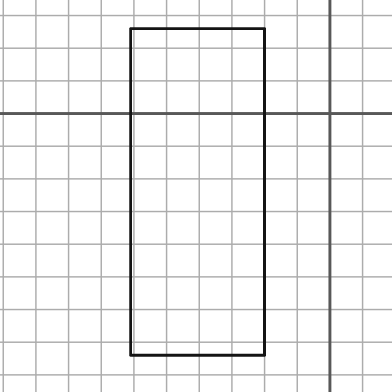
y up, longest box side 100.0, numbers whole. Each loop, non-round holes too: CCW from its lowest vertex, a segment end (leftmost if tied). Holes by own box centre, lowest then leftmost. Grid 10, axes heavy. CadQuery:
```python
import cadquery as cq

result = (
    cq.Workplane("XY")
    .moveTo(-61.0, -74.0)
    .lineTo(-20.0, -74.0)
    .lineTo(-20.0, 26.0)
    .lineTo(-61.0, 26.0)
    .close()
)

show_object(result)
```